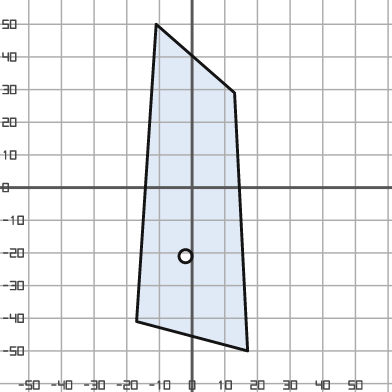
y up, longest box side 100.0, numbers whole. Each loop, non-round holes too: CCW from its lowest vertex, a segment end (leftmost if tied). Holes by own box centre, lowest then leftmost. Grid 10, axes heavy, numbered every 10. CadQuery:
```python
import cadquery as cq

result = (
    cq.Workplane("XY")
    .moveTo(17.0, -50.0)
    .lineTo(13.0, 29.0)
    .lineTo(-11.0, 50.0)
    .lineTo(-17.0, -41.0)
    .close()
    .moveTo(-2.0, -21.0)
    .circle(2.0)
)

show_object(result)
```